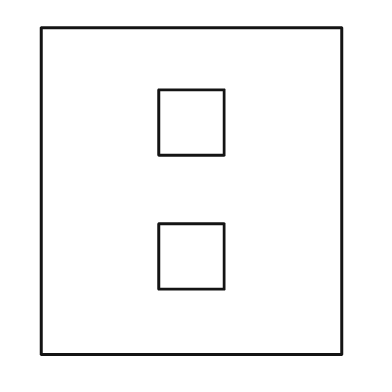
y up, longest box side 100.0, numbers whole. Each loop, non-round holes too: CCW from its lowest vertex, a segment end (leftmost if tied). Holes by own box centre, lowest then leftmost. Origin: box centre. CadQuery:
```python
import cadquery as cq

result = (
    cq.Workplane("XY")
    .moveTo(-46.0, -50.0)
    .lineTo(46.0, -50.0)
    .lineTo(46.0, 50.0)
    .lineTo(-46.0, 50.0)
    .close()
    .moveTo(-10.0, -30.0)
    .lineTo(10.0, -30.0)
    .lineTo(10.0, -10.0)
    .lineTo(-10.0, -10.0)
    .close()
    .moveTo(-10.0, 11.0)
    .lineTo(10.0, 11.0)
    .lineTo(10.0, 31.0)
    .lineTo(-10.0, 31.0)
    .close()
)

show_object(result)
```